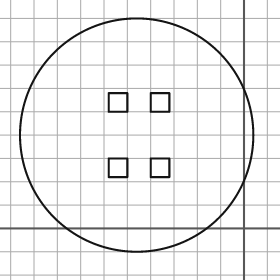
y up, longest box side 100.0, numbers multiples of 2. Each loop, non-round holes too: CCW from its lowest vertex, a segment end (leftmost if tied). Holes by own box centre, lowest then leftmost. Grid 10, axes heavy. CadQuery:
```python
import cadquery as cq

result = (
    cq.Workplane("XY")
    .moveTo(-46.0, 40.0)
    .circle(50.0)
    .moveTo(-58.0, 22.0)
    .lineTo(-50.0, 22.0)
    .lineTo(-50.0, 30.0)
    .lineTo(-58.0, 30.0)
    .close()
    .moveTo(-40.0, 22.0)
    .lineTo(-32.0, 22.0)
    .lineTo(-32.0, 30.0)
    .lineTo(-40.0, 30.0)
    .close()
    .moveTo(-58.0, 50.0)
    .lineTo(-50.0, 50.0)
    .lineTo(-50.0, 58.0)
    .lineTo(-58.0, 58.0)
    .close()
    .moveTo(-40.0, 50.0)
    .lineTo(-32.0, 50.0)
    .lineTo(-32.0, 58.0)
    .lineTo(-40.0, 58.0)
    .close()
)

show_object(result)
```